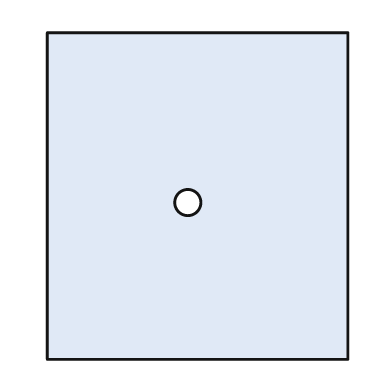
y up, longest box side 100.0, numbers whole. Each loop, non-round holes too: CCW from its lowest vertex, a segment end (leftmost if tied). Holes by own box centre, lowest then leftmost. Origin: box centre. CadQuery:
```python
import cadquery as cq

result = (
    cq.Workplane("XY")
    .moveTo(-46.0, -50.0)
    .lineTo(46.0, -50.0)
    .lineTo(46.0, 50.0)
    .lineTo(-46.0, 50.0)
    .close()
    .moveTo(-3.0, -2.0)
    .circle(4.0)
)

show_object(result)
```